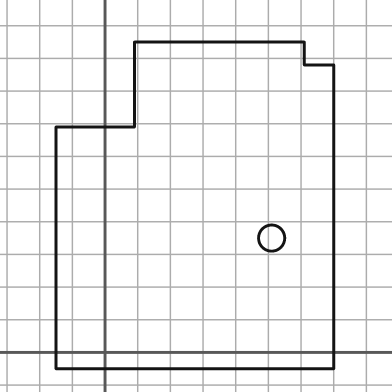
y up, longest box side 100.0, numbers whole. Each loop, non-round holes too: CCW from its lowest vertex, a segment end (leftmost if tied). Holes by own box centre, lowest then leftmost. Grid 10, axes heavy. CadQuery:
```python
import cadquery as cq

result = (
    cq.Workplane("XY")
    .moveTo(-15.0, -5.0)
    .lineTo(70.0, -5.0)
    .lineTo(70.0, 88.0)
    .lineTo(61.0, 88.0)
    .lineTo(61.0, 95.0)
    .lineTo(9.0, 95.0)
    .lineTo(9.0, 69.0)
    .lineTo(-15.0, 69.0)
    .close()
    .moveTo(51.0, 35.0)
    .circle(4.0)
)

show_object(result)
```